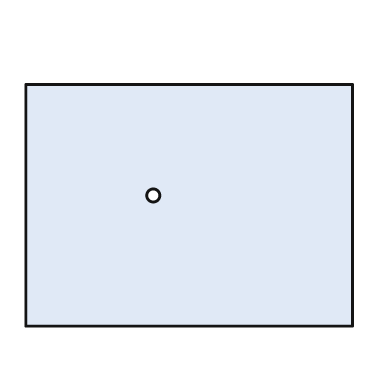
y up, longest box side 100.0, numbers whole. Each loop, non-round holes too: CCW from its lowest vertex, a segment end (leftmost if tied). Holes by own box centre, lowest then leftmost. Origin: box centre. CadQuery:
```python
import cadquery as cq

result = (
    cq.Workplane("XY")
    .moveTo(-50.0, -37.0)
    .lineTo(50.0, -37.0)
    .lineTo(50.0, 37.0)
    .lineTo(-50.0, 37.0)
    .close()
    .moveTo(-11.0, 3.0)
    .circle(2.0)
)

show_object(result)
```